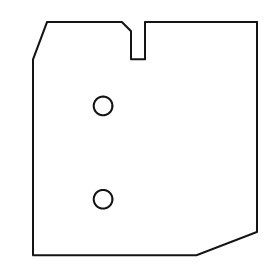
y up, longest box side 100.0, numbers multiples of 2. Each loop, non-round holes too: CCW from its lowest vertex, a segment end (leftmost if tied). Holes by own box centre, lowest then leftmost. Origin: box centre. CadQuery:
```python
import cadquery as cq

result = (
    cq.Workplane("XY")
    .moveTo(-48.0, -50.0)
    .lineTo(22.0, -50.0)
    .lineTo(48.0, -40.0)
    .lineTo(48.0, 50.0)
    .lineTo(0.0, 50.0)
    .lineTo(0.0, 34.0)
    .lineTo(-6.0, 34.0)
    .lineTo(-6.0, 46.0)
    .lineTo(-10.0, 50.0)
    .lineTo(-42.0, 50.0)
    .lineTo(-48.0, 34.0)
    .close()
    .moveTo(-18.0, -26.0)
    .circle(4.0)
    .moveTo(-18.0, 14.0)
    .circle(4.0)
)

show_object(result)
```